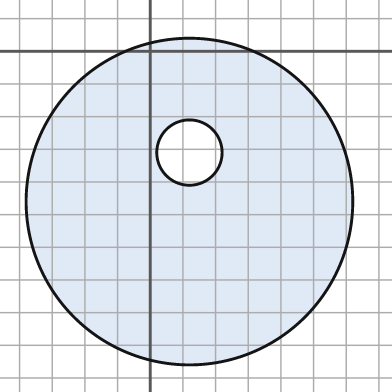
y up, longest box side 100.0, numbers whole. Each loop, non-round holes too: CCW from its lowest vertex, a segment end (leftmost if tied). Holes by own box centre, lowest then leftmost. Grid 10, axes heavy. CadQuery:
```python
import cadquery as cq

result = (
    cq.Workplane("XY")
    .moveTo(12.0, -46.0)
    .circle(50.0)
    .moveTo(12.0, -31.0)
    .circle(10.0)
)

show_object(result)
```